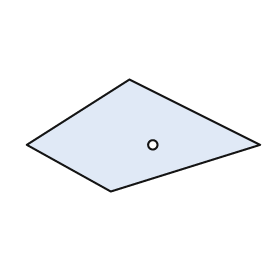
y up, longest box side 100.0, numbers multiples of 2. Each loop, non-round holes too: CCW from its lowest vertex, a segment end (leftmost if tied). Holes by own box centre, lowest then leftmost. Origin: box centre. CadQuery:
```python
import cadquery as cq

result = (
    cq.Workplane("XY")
    .moveTo(-14.0, -24.0)
    .lineTo(50.0, -4.0)
    .lineTo(-6.0, 24.0)
    .lineTo(-50.0, -4.0)
    .close()
    .moveTo(4.0, -4.0)
    .circle(2.0)
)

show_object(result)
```